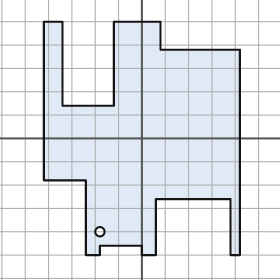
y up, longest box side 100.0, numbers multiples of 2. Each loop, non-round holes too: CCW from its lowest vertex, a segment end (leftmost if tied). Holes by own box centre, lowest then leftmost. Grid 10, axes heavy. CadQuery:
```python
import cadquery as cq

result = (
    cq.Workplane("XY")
    .moveTo(-24.0, -50.0)
    .lineTo(-18.0, -50.0)
    .lineTo(-18.0, -46.0)
    .lineTo(0.0, -46.0)
    .lineTo(0.0, -50.0)
    .lineTo(6.0, -50.0)
    .lineTo(6.0, -26.0)
    .lineTo(38.0, -26.0)
    .lineTo(38.0, -50.0)
    .lineTo(42.0, -50.0)
    .lineTo(42.0, 38.0)
    .lineTo(8.0, 38.0)
    .lineTo(8.0, 50.0)
    .lineTo(-12.0, 50.0)
    .lineTo(-12.0, 14.0)
    .lineTo(-34.0, 14.0)
    .lineTo(-34.0, 50.0)
    .lineTo(-42.0, 50.0)
    .lineTo(-42.0, -18.0)
    .lineTo(-24.0, -18.0)
    .close()
    .moveTo(-18.0, -40.0)
    .circle(2.0)
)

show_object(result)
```